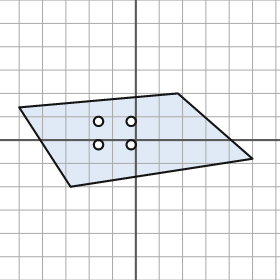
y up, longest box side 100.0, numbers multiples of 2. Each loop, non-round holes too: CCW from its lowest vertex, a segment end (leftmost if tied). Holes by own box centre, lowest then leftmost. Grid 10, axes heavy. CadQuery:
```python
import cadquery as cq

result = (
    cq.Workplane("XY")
    .moveTo(-28.0, -20.0)
    .lineTo(50.0, -8.0)
    .lineTo(18.0, 20.0)
    .lineTo(-50.0, 14.0)
    .close()
    .moveTo(-16.0, -2.0)
    .circle(2.0)
    .moveTo(-2.0, -2.0)
    .circle(2.0)
    .moveTo(-16.0, 8.0)
    .circle(2.0)
    .moveTo(-2.0, 8.0)
    .circle(2.0)
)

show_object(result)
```